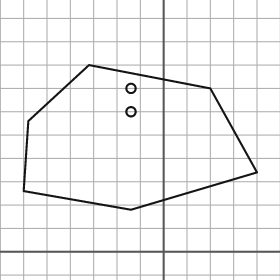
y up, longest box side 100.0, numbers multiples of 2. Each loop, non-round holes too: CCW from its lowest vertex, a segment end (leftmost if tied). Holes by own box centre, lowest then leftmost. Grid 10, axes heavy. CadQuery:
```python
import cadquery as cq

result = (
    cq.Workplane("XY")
    .moveTo(-14.0, 18.0)
    .lineTo(40.0, 34.0)
    .lineTo(20.0, 70.0)
    .lineTo(-32.0, 80.0)
    .lineTo(-58.0, 56.0)
    .lineTo(-60.0, 26.0)
    .close()
    .moveTo(-14.0, 60.0)
    .circle(2.0)
    .moveTo(-14.0, 70.0)
    .circle(2.0)
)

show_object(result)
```